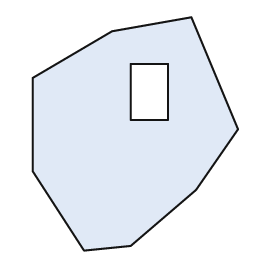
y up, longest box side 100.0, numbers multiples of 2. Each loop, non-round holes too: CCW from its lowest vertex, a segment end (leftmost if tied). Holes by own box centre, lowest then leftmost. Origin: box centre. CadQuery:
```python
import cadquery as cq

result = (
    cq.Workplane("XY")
    .moveTo(-22.0, -50.0)
    .lineTo(-2.0, -48.0)
    .lineTo(26.0, -24.0)
    .lineTo(44.0, 2.0)
    .lineTo(24.0, 50.0)
    .lineTo(-10.0, 44.0)
    .lineTo(-44.0, 24.0)
    .lineTo(-44.0, -16.0)
    .close()
    .moveTo(-2.0, 6.0)
    .lineTo(14.0, 6.0)
    .lineTo(14.0, 30.0)
    .lineTo(-2.0, 30.0)
    .close()
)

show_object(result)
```